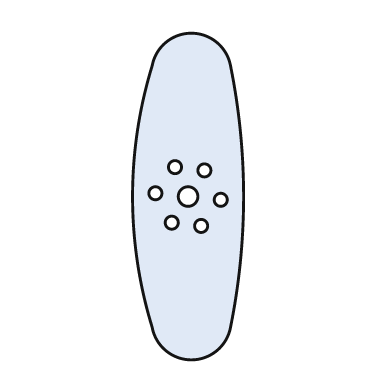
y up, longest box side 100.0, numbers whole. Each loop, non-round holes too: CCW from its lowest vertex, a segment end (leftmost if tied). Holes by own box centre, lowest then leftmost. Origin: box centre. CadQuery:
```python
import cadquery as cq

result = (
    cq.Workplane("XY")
    .moveTo(-11.0, -40.0)
    .threePointArc((1.0, -50.0), (13.0, -40.0))
    .threePointArc((17.0, 0.0), (13.0, 40.0))
    .threePointArc((1.0, 50.0), (-11.0, 40.0))
    .threePointArc((-17.0, 0.0), (-11.0, -40.0))
    .close()
    .moveTo(4.0, -9.0)
    .circle(2.0)
    .moveTo(-5.0, -8.0)
    .circle(2.0)
    .moveTo(10.0, -1.0)
    .circle(2.0)
    .moveTo(0.0, 0.0)
    .circle(3.0)
    .moveTo(-10.0, 1.0)
    .circle(2.0)
    .moveTo(5.0, 8.0)
    .circle(2.0)
    .moveTo(-4.0, 9.0)
    .circle(2.0)
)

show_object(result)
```